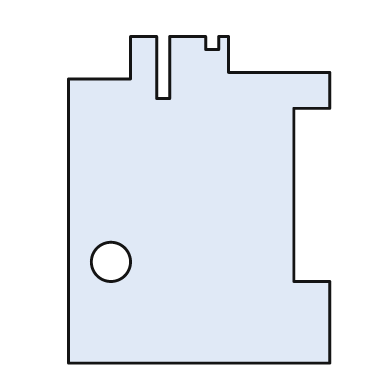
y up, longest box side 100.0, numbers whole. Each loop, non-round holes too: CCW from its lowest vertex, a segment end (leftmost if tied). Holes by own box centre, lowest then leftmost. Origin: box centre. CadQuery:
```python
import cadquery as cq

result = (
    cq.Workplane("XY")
    .moveTo(-40.0, -50.0)
    .lineTo(40.0, -50.0)
    .lineTo(40.0, -25.0)
    .lineTo(29.0, -25.0)
    .lineTo(29.0, 28.0)
    .lineTo(40.0, 28.0)
    .lineTo(40.0, 39.0)
    .lineTo(9.0, 39.0)
    .lineTo(9.0, 50.0)
    .lineTo(6.0, 50.0)
    .lineTo(6.0, 46.0)
    .lineTo(2.0, 46.0)
    .lineTo(2.0, 50.0)
    .lineTo(-9.0, 50.0)
    .lineTo(-9.0, 31.0)
    .lineTo(-13.0, 31.0)
    .lineTo(-13.0, 50.0)
    .lineTo(-21.0, 50.0)
    .lineTo(-21.0, 37.0)
    .lineTo(-40.0, 37.0)
    .close()
    .moveTo(-27.0, -19.0)
    .circle(6.0)
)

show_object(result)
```